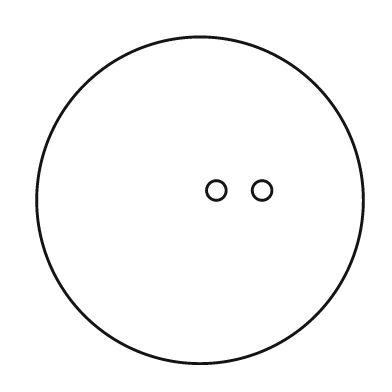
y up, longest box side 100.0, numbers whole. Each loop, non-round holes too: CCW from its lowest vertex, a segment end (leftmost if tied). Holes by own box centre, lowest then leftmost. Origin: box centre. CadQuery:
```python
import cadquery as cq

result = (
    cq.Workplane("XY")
    .moveTo(0.0, 0.0)
    .circle(50.0)
    .moveTo(5.0, 3.0)
    .circle(3.0)
    .moveTo(19.0, 3.0)
    .circle(3.0)
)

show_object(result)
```